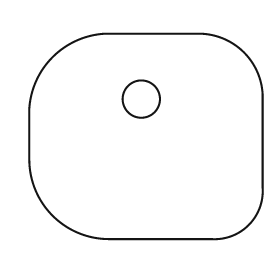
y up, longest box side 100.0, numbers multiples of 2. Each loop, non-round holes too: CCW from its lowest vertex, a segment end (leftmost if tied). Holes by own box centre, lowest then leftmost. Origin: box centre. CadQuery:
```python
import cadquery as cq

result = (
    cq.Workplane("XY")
    .moveTo(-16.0, -44.0)
    .lineTo(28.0, -44.0)
    .threePointArc((44.0, -38.0), (50.0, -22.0))
    .lineTo(50.0, 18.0)
    .threePointArc((42.0, 36.0), (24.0, 44.0))
    .lineTo(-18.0, 44.0)
    .threePointArc((-40.0, 34.0), (-50.0, 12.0))
    .lineTo(-50.0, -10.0)
    .threePointArc((-40.0, -34.0), (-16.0, -44.0))
    .close()
    .moveTo(-2.0, 16.0)
    .circle(8.0)
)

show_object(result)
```